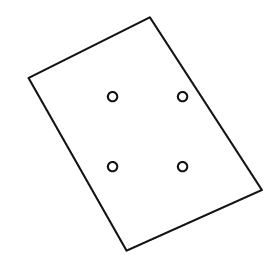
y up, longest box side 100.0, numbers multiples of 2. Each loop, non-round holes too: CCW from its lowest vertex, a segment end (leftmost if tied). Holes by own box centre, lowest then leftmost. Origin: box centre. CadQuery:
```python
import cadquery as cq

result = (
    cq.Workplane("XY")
    .moveTo(-8.0, -50.0)
    .lineTo(50.0, -24.0)
    .lineTo(2.0, 50.0)
    .lineTo(-50.0, 24.0)
    .close()
    .moveTo(-14.0, -14.0)
    .circle(2.0)
    .moveTo(16.0, -14.0)
    .circle(2.0)
    .moveTo(-14.0, 16.0)
    .circle(2.0)
    .moveTo(16.0, 16.0)
    .circle(2.0)
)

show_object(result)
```